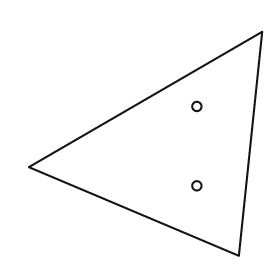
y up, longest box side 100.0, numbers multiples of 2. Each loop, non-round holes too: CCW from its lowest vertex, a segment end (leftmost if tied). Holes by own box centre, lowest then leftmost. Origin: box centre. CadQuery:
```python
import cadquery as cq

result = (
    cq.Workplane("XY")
    .moveTo(40.0, -48.0)
    .lineTo(50.0, 48.0)
    .lineTo(-50.0, -10.0)
    .close()
    .moveTo(22.0, -18.0)
    .circle(2.0)
    .moveTo(22.0, 16.0)
    .circle(2.0)
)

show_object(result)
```